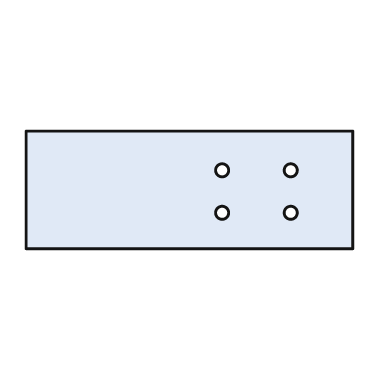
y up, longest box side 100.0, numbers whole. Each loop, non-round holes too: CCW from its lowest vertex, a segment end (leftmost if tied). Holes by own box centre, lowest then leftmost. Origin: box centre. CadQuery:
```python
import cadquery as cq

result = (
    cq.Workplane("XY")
    .moveTo(-50.0, -18.0)
    .lineTo(50.0, -18.0)
    .lineTo(50.0, 18.0)
    .lineTo(-50.0, 18.0)
    .close()
    .moveTo(10.0, -7.0)
    .circle(2.0)
    .moveTo(31.0, -7.0)
    .circle(2.0)
    .moveTo(10.0, 6.0)
    .circle(2.0)
    .moveTo(31.0, 6.0)
    .circle(2.0)
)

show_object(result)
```